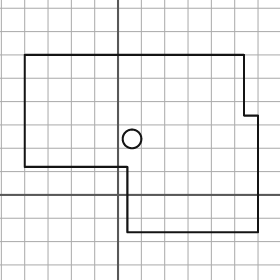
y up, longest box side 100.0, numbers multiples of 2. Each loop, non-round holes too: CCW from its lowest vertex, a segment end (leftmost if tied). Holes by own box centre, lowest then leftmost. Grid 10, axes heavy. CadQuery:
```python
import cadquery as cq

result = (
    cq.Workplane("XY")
    .moveTo(4.0, -16.0)
    .lineTo(60.0, -16.0)
    .lineTo(60.0, 34.0)
    .lineTo(54.0, 34.0)
    .lineTo(54.0, 60.0)
    .lineTo(-40.0, 60.0)
    .lineTo(-40.0, 12.0)
    .lineTo(4.0, 12.0)
    .close()
    .moveTo(6.0, 24.0)
    .circle(4.0)
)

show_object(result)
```